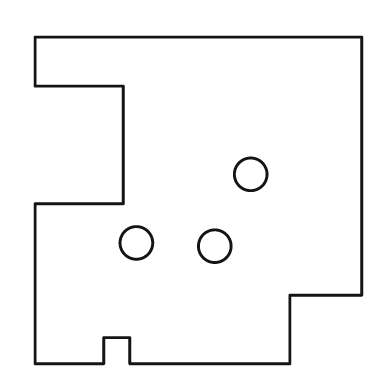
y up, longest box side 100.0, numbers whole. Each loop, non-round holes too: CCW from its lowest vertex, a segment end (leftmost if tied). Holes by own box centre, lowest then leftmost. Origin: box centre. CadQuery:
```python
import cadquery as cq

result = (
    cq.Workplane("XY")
    .moveTo(-50.0, -50.0)
    .lineTo(-29.0, -50.0)
    .lineTo(-29.0, -42.0)
    .lineTo(-21.0, -42.0)
    .lineTo(-21.0, -50.0)
    .lineTo(28.0, -50.0)
    .lineTo(28.0, -29.0)
    .lineTo(50.0, -29.0)
    .lineTo(50.0, 50.0)
    .lineTo(-50.0, 50.0)
    .lineTo(-50.0, 35.0)
    .lineTo(-23.0, 35.0)
    .lineTo(-23.0, -1.0)
    .lineTo(-50.0, -1.0)
    .close()
    .moveTo(5.0, -14.0)
    .circle(5.0)
    .moveTo(-19.0, -13.0)
    .circle(5.0)
    .moveTo(16.0, 8.0)
    .circle(5.0)
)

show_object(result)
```